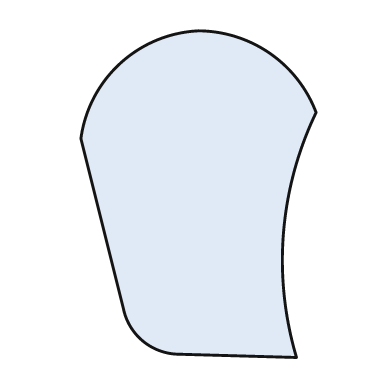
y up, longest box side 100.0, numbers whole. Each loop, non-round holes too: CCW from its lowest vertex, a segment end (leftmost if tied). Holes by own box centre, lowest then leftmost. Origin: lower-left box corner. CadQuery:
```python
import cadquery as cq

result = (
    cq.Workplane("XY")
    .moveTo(66.0, 0.0)
    .threePointArc((62.0, 38.0), (72.0, 75.0))
    .threePointArc((58.0, 93.0), (36.0, 100.0))
    .threePointArc((12.0, 90.0), (0.0, 67.0))
    .lineTo(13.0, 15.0)
    .threePointArc((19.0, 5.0), (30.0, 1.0))
    .close()
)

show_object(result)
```